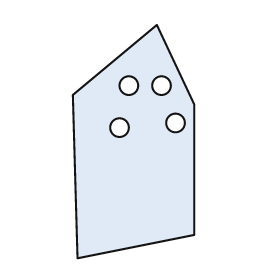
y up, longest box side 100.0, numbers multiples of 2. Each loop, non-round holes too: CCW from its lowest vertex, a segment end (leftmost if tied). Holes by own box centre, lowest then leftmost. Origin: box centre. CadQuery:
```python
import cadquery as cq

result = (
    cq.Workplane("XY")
    .moveTo(-24.0, -50.0)
    .lineTo(26.0, -40.0)
    .lineTo(26.0, 16.0)
    .lineTo(10.0, 50.0)
    .lineTo(-26.0, 20.0)
    .close()
    .moveTo(-6.0, 6.0)
    .circle(4.0)
    .moveTo(18.0, 8.0)
    .circle(4.0)
    .moveTo(-2.0, 24.0)
    .circle(4.0)
    .moveTo(12.0, 24.0)
    .circle(4.0)
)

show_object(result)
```